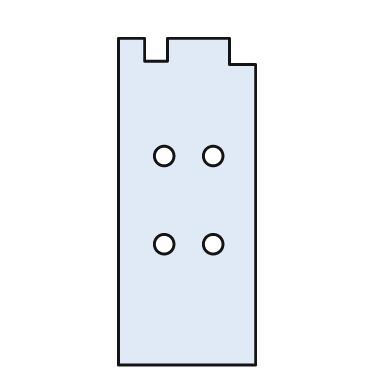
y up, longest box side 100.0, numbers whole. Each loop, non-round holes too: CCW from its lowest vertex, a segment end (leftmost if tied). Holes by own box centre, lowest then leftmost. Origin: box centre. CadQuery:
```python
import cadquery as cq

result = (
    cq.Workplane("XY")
    .moveTo(-21.0, -50.0)
    .lineTo(21.0, -50.0)
    .lineTo(21.0, 42.0)
    .lineTo(13.0, 42.0)
    .lineTo(13.0, 50.0)
    .lineTo(-6.0, 50.0)
    .lineTo(-6.0, 43.0)
    .lineTo(-13.0, 43.0)
    .lineTo(-13.0, 50.0)
    .lineTo(-21.0, 50.0)
    .close()
    .moveTo(-7.0, -13.0)
    .circle(3.0)
    .moveTo(8.0, -13.0)
    .circle(3.0)
    .moveTo(-7.0, 14.0)
    .circle(3.0)
    .moveTo(8.0, 14.0)
    .circle(3.0)
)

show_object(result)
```